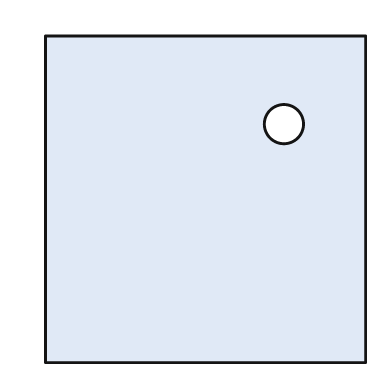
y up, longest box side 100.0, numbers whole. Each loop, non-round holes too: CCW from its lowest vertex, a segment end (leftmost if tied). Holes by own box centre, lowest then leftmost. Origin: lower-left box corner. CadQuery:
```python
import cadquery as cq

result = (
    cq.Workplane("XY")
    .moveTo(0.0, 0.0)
    .lineTo(98.0, 0.0)
    .lineTo(98.0, 100.0)
    .lineTo(0.0, 100.0)
    .close()
    .moveTo(73.0, 73.0)
    .circle(6.0)
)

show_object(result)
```